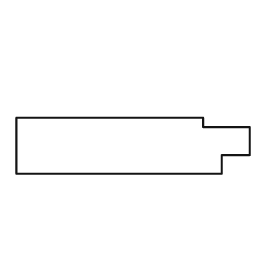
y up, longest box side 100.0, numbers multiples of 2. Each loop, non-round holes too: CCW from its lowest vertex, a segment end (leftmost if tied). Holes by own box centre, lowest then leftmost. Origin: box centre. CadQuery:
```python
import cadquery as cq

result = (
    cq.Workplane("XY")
    .moveTo(-50.0, -12.0)
    .lineTo(38.0, -12.0)
    .lineTo(38.0, -4.0)
    .lineTo(50.0, -4.0)
    .lineTo(50.0, 8.0)
    .lineTo(30.0, 8.0)
    .lineTo(30.0, 12.0)
    .lineTo(-50.0, 12.0)
    .close()
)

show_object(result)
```